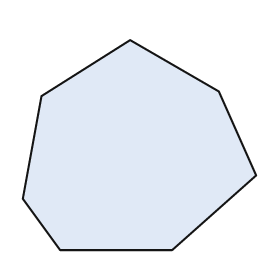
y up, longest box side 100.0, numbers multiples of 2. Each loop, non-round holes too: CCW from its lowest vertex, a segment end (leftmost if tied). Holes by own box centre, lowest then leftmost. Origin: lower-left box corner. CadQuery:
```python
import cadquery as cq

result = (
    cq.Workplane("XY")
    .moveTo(16.0, 0.0)
    .lineTo(64.0, 0.0)
    .lineTo(100.0, 32.0)
    .lineTo(84.0, 68.0)
    .lineTo(46.0, 90.0)
    .lineTo(8.0, 66.0)
    .lineTo(0.0, 22.0)
    .close()
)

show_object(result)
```